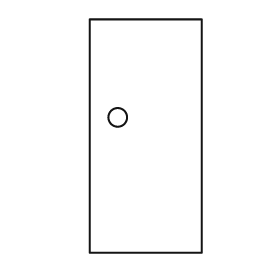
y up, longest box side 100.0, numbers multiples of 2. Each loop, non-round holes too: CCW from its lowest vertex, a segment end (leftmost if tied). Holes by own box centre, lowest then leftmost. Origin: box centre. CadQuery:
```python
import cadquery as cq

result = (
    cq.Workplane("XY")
    .moveTo(-24.0, -50.0)
    .lineTo(24.0, -50.0)
    .lineTo(24.0, 50.0)
    .lineTo(-24.0, 50.0)
    .close()
    .moveTo(-12.0, 8.0)
    .circle(4.0)
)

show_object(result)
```